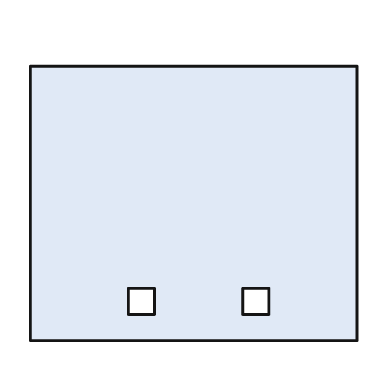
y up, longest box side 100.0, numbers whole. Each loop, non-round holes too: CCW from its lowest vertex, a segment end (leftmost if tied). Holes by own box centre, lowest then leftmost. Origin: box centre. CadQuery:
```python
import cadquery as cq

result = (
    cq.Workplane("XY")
    .moveTo(-50.0, -42.0)
    .lineTo(50.0, -42.0)
    .lineTo(50.0, 42.0)
    .lineTo(-50.0, 42.0)
    .close()
    .moveTo(-20.0, -34.0)
    .lineTo(-12.0, -34.0)
    .lineTo(-12.0, -26.0)
    .lineTo(-20.0, -26.0)
    .close()
    .moveTo(15.0, -34.0)
    .lineTo(23.0, -34.0)
    .lineTo(23.0, -26.0)
    .lineTo(15.0, -26.0)
    .close()
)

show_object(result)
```